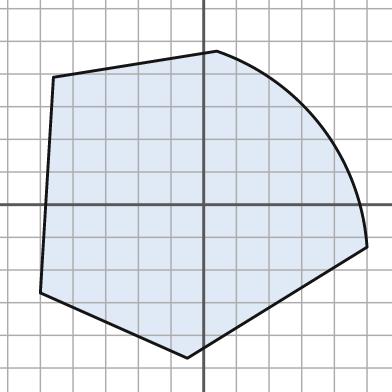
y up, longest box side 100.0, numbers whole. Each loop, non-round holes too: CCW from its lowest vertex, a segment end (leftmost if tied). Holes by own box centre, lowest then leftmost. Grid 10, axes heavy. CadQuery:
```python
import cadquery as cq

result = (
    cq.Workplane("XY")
    .moveTo(-5.0, -47.0)
    .lineTo(50.0, -13.0)
    .threePointArc((36.0, 24.0), (4.0, 47.0))
    .lineTo(-46.0, 39.0)
    .lineTo(-50.0, -27.0)
    .close()
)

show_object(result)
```